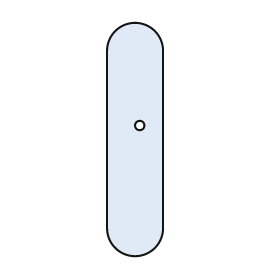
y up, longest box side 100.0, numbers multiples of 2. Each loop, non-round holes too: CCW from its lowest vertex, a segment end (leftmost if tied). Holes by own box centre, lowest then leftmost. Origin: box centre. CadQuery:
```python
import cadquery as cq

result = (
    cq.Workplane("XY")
    .moveTo(-12.0, -38.0)
    .threePointArc((0.0, -50.0), (12.0, -38.0))
    .lineTo(12.0, 38.0)
    .threePointArc((0.0, 50.0), (-12.0, 38.0))
    .close()
    .moveTo(2.0, 6.0)
    .circle(2.0)
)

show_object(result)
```